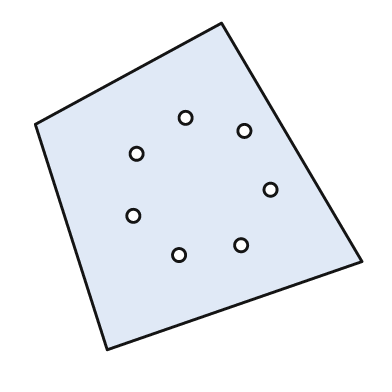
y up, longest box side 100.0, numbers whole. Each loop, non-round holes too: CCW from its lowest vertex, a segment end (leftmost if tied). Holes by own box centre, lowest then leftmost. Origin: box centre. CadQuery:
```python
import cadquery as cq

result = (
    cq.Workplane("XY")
    .moveTo(-28.0, -50.0)
    .lineTo(50.0, -23.0)
    .lineTo(7.0, 50.0)
    .lineTo(-50.0, 19.0)
    .close()
    .moveTo(-6.0, -21.0)
    .circle(2.0)
    .moveTo(13.0, -18.0)
    .circle(2.0)
    .moveTo(-20.0, -9.0)
    .circle(2.0)
    .moveTo(22.0, -1.0)
    .circle(2.0)
    .moveTo(-19.0, 10.0)
    .circle(2.0)
    .moveTo(14.0, 17.0)
    .circle(2.0)
    .moveTo(-4.0, 21.0)
    .circle(2.0)
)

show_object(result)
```